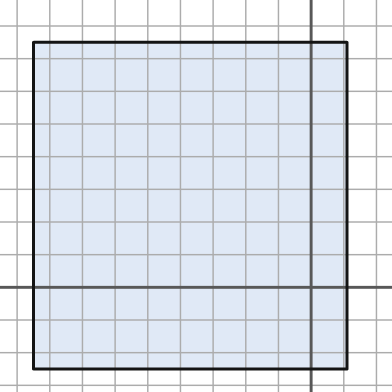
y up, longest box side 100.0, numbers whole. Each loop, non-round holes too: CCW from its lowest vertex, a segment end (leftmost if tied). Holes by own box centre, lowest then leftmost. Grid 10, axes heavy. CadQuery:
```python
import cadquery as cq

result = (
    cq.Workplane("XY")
    .moveTo(-85.0, -25.0)
    .lineTo(11.0, -25.0)
    .lineTo(11.0, 75.0)
    .lineTo(-85.0, 75.0)
    .close()
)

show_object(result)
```